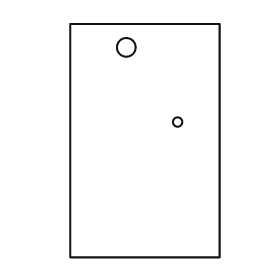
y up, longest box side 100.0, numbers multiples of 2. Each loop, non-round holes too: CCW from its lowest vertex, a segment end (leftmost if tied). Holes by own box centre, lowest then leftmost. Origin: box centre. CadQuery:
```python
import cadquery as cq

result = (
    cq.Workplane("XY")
    .moveTo(-32.0, -50.0)
    .lineTo(32.0, -50.0)
    .lineTo(32.0, 50.0)
    .lineTo(-32.0, 50.0)
    .close()
    .moveTo(14.0, 8.0)
    .circle(2.0)
    .moveTo(-8.0, 40.0)
    .circle(4.0)
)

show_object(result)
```